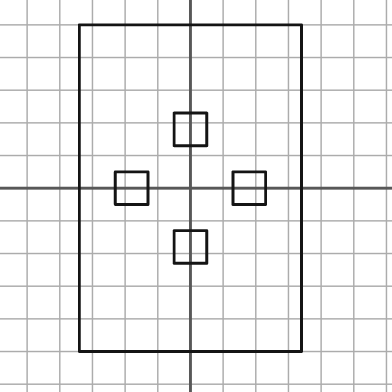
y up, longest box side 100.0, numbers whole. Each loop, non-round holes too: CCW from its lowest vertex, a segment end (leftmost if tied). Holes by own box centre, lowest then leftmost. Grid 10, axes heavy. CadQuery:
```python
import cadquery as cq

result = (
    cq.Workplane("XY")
    .moveTo(-34.0, -50.0)
    .lineTo(34.0, -50.0)
    .lineTo(34.0, 50.0)
    .lineTo(-34.0, 50.0)
    .close()
    .moveTo(-5.0, -23.0)
    .lineTo(5.0, -23.0)
    .lineTo(5.0, -13.0)
    .lineTo(-5.0, -13.0)
    .close()
    .moveTo(-23.0, -5.0)
    .lineTo(-13.0, -5.0)
    .lineTo(-13.0, 5.0)
    .lineTo(-23.0, 5.0)
    .close()
    .moveTo(13.0, -5.0)
    .lineTo(23.0, -5.0)
    .lineTo(23.0, 5.0)
    .lineTo(13.0, 5.0)
    .close()
    .moveTo(-5.0, 13.0)
    .lineTo(5.0, 13.0)
    .lineTo(5.0, 23.0)
    .lineTo(-5.0, 23.0)
    .close()
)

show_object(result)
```